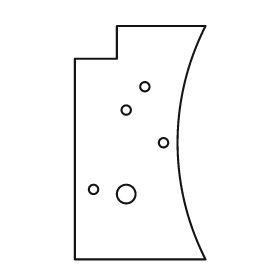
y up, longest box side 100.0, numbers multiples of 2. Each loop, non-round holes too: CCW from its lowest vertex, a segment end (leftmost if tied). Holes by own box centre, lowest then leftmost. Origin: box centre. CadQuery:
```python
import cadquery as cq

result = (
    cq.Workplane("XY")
    .moveTo(-28.0, -50.0)
    .lineTo(28.0, -50.0)
    .threePointArc((16.0, 0.0), (28.0, 50.0))
    .lineTo(-10.0, 50.0)
    .lineTo(-10.0, 36.0)
    .lineTo(-28.0, 36.0)
    .close()
    .moveTo(-6.0, -22.0)
    .circle(4.0)
    .moveTo(-20.0, -20.0)
    .circle(2.0)
    .moveTo(10.0, 0.0)
    .circle(2.0)
    .moveTo(-6.0, 14.0)
    .circle(2.0)
    .moveTo(2.0, 24.0)
    .circle(2.0)
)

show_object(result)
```